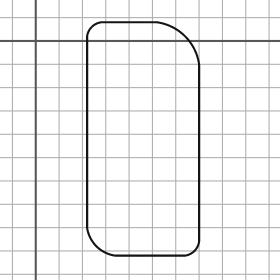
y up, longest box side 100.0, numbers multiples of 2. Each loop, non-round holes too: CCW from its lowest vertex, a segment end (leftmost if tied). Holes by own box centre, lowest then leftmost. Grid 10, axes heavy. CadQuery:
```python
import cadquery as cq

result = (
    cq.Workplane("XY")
    .moveTo(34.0, -92.0)
    .lineTo(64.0, -92.0)
    .threePointArc((68.0, -90.0), (70.0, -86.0))
    .lineTo(70.0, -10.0)
    .threePointArc((64.0, 2.0), (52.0, 8.0))
    .lineTo(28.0, 8.0)
    .threePointArc((24.0, 6.0), (22.0, 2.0))
    .lineTo(22.0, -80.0)
    .threePointArc((26.0, -88.0), (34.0, -92.0))
    .close()
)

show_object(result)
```